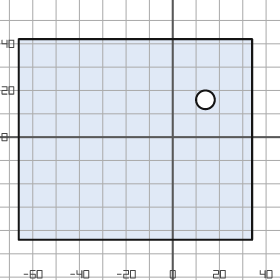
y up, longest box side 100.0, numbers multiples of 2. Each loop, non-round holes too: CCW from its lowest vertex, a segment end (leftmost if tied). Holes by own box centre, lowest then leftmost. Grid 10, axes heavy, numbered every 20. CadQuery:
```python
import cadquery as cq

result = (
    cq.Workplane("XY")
    .moveTo(-66.0, -44.0)
    .lineTo(34.0, -44.0)
    .lineTo(34.0, 42.0)
    .lineTo(-66.0, 42.0)
    .close()
    .moveTo(14.0, 16.0)
    .circle(4.0)
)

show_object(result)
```